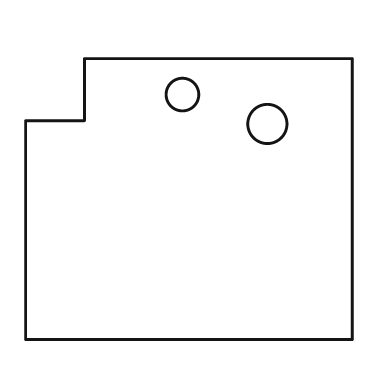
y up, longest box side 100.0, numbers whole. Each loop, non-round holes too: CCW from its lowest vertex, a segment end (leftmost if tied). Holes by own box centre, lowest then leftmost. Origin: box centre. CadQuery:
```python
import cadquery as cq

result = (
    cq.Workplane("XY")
    .moveTo(-50.0, -43.0)
    .lineTo(50.0, -43.0)
    .lineTo(50.0, 43.0)
    .lineTo(-32.0, 43.0)
    .lineTo(-32.0, 24.0)
    .lineTo(-50.0, 24.0)
    .close()
    .moveTo(24.0, 23.0)
    .circle(6.0)
    .moveTo(-2.0, 32.0)
    .circle(5.0)
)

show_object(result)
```